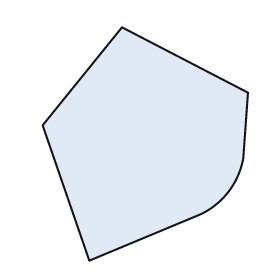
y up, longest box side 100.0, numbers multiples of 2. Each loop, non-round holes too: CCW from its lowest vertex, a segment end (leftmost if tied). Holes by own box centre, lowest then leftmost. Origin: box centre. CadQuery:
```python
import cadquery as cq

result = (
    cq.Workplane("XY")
    .moveTo(-24.0, -50.0)
    .lineTo(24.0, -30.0)
    .threePointArc((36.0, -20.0), (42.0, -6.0))
    .lineTo(44.0, 22.0)
    .lineTo(-10.0, 50.0)
    .lineTo(-44.0, 8.0)
    .close()
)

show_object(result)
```